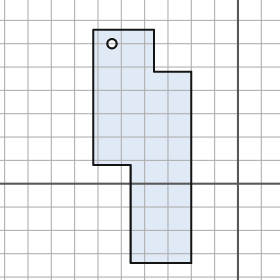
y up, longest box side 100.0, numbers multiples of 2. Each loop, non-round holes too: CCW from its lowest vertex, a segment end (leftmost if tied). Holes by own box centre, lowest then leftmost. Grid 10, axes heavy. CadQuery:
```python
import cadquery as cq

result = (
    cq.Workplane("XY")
    .moveTo(-46.0, -34.0)
    .lineTo(-20.0, -34.0)
    .lineTo(-20.0, 48.0)
    .lineTo(-36.0, 48.0)
    .lineTo(-36.0, 66.0)
    .lineTo(-62.0, 66.0)
    .lineTo(-62.0, 8.0)
    .lineTo(-46.0, 8.0)
    .close()
    .moveTo(-54.0, 60.0)
    .circle(2.0)
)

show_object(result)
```